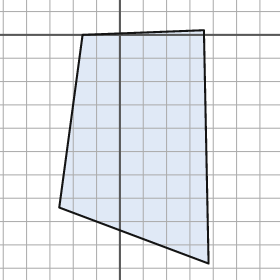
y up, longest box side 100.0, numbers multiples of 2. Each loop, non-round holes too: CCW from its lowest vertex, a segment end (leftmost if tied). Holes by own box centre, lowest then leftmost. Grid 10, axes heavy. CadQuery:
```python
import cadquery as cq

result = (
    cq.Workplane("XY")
    .moveTo(38.0, -98.0)
    .lineTo(36.0, 2.0)
    .lineTo(-16.0, 0.0)
    .lineTo(-26.0, -74.0)
    .close()
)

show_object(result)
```